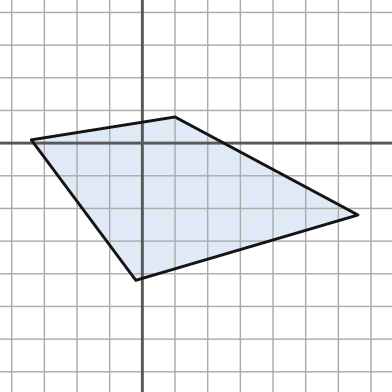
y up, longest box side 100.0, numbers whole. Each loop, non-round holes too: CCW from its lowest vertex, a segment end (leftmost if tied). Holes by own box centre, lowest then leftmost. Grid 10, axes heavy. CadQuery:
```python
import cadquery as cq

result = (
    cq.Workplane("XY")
    .moveTo(-2.0, -42.0)
    .lineTo(66.0, -22.0)
    .lineTo(10.0, 8.0)
    .lineTo(-34.0, 1.0)
    .close()
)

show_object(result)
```